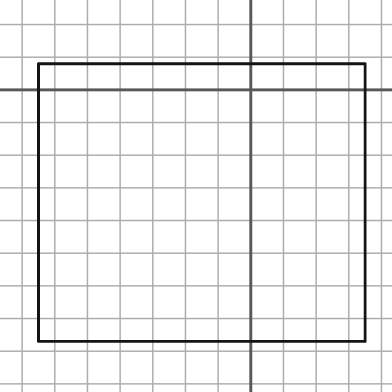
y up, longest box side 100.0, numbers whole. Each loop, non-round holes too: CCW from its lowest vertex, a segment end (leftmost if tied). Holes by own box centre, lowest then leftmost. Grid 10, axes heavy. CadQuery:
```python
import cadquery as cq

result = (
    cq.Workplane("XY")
    .moveTo(-65.0, -77.0)
    .lineTo(35.0, -77.0)
    .lineTo(35.0, 8.0)
    .lineTo(-65.0, 8.0)
    .close()
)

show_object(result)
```